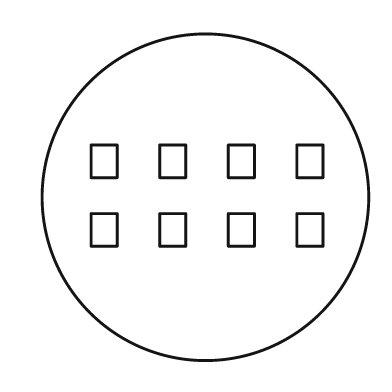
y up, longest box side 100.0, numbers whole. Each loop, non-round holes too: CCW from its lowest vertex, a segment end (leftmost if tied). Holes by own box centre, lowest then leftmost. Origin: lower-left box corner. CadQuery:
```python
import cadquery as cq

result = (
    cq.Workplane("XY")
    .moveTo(50.0, 50.0)
    .circle(50.0)
    .moveTo(15.0, 35.0)
    .lineTo(23.0, 35.0)
    .lineTo(23.0, 45.0)
    .lineTo(15.0, 45.0)
    .close()
    .moveTo(36.0, 35.0)
    .lineTo(44.0, 35.0)
    .lineTo(44.0, 45.0)
    .lineTo(36.0, 45.0)
    .close()
    .moveTo(57.0, 35.0)
    .lineTo(65.0, 35.0)
    .lineTo(65.0, 45.0)
    .lineTo(57.0, 45.0)
    .close()
    .moveTo(78.0, 35.0)
    .lineTo(86.0, 35.0)
    .lineTo(86.0, 45.0)
    .lineTo(78.0, 45.0)
    .close()
    .moveTo(15.0, 56.0)
    .lineTo(23.0, 56.0)
    .lineTo(23.0, 66.0)
    .lineTo(15.0, 66.0)
    .close()
    .moveTo(36.0, 56.0)
    .lineTo(44.0, 56.0)
    .lineTo(44.0, 66.0)
    .lineTo(36.0, 66.0)
    .close()
    .moveTo(57.0, 56.0)
    .lineTo(65.0, 56.0)
    .lineTo(65.0, 66.0)
    .lineTo(57.0, 66.0)
    .close()
    .moveTo(78.0, 56.0)
    .lineTo(86.0, 56.0)
    .lineTo(86.0, 66.0)
    .lineTo(78.0, 66.0)
    .close()
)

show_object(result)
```